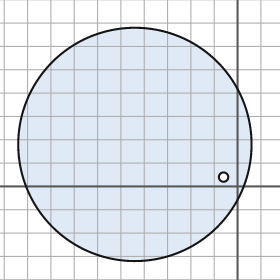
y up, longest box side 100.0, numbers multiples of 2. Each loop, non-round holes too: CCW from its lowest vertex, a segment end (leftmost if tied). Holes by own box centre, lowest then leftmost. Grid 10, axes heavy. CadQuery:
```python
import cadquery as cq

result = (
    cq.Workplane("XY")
    .moveTo(-44.0, 18.0)
    .circle(50.0)
    .moveTo(-6.0, 4.0)
    .circle(2.0)
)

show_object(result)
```